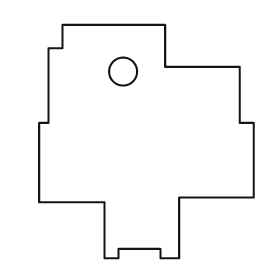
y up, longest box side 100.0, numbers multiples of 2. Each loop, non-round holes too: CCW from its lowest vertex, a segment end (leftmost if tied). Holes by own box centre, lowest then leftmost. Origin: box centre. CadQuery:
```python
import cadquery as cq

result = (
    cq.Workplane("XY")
    .moveTo(-18.0, -50.0)
    .lineTo(-12.0, -50.0)
    .lineTo(-12.0, -46.0)
    .lineTo(6.0, -46.0)
    .lineTo(6.0, -50.0)
    .lineTo(14.0, -50.0)
    .lineTo(14.0, -24.0)
    .lineTo(46.0, -24.0)
    .lineTo(46.0, 8.0)
    .lineTo(40.0, 8.0)
    .lineTo(40.0, 32.0)
    .lineTo(8.0, 32.0)
    .lineTo(8.0, 50.0)
    .lineTo(-36.0, 50.0)
    .lineTo(-36.0, 40.0)
    .lineTo(-42.0, 40.0)
    .lineTo(-42.0, 8.0)
    .lineTo(-46.0, 8.0)
    .lineTo(-46.0, -26.0)
    .lineTo(-18.0, -26.0)
    .close()
    .moveTo(-10.0, 30.0)
    .circle(6.0)
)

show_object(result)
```